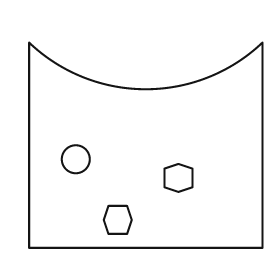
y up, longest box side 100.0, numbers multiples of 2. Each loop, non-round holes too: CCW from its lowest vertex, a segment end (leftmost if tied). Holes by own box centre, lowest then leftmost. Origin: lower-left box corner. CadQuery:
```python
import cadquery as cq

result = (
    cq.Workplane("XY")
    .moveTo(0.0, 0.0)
    .lineTo(100.0, 0.0)
    .lineTo(100.0, 88.0)
    .threePointArc((50.0, 68.0), (0.0, 88.0))
    .close()
    .moveTo(34.0, 6.0)
    .lineTo(42.0, 6.0)
    .lineTo(44.0, 12.0)
    .lineTo(42.0, 18.0)
    .lineTo(34.0, 18.0)
    .lineTo(32.0, 12.0)
    .close()
    .moveTo(64.0, 24.0)
    .lineTo(70.0, 26.0)
    .lineTo(70.0, 34.0)
    .lineTo(64.0, 36.0)
    .lineTo(58.0, 34.0)
    .lineTo(58.0, 26.0)
    .close()
    .moveTo(20.0, 38.0)
    .circle(6.0)
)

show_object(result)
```